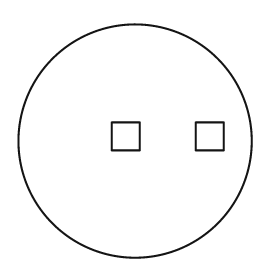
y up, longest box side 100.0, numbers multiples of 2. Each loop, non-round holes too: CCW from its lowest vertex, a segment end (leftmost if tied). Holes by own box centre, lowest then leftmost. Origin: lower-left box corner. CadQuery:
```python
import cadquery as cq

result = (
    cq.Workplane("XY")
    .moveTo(50.0, 50.0)
    .circle(50.0)
    .moveTo(40.0, 46.0)
    .lineTo(52.0, 46.0)
    .lineTo(52.0, 58.0)
    .lineTo(40.0, 58.0)
    .close()
    .moveTo(76.0, 46.0)
    .lineTo(88.0, 46.0)
    .lineTo(88.0, 58.0)
    .lineTo(76.0, 58.0)
    .close()
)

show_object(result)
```